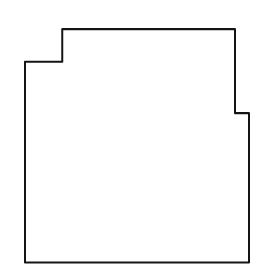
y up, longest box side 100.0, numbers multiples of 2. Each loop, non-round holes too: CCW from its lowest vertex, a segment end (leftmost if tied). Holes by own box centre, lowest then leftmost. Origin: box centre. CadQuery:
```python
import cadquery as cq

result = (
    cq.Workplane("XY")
    .moveTo(-48.0, -50.0)
    .lineTo(48.0, -50.0)
    .lineTo(48.0, 14.0)
    .lineTo(42.0, 14.0)
    .lineTo(42.0, 50.0)
    .lineTo(-32.0, 50.0)
    .lineTo(-32.0, 36.0)
    .lineTo(-48.0, 36.0)
    .close()
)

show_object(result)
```